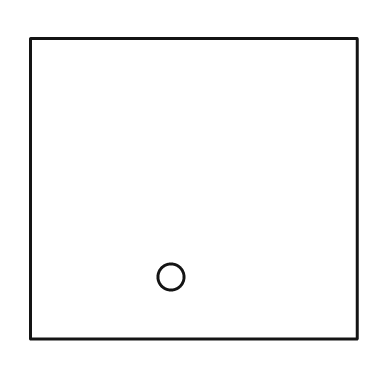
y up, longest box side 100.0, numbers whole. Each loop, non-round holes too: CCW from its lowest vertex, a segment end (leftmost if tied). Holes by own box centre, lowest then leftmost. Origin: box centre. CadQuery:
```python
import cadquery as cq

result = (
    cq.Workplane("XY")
    .moveTo(-50.0, -46.0)
    .lineTo(50.0, -46.0)
    .lineTo(50.0, 46.0)
    .lineTo(-50.0, 46.0)
    .close()
    .moveTo(-7.0, -27.0)
    .circle(4.0)
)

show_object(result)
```